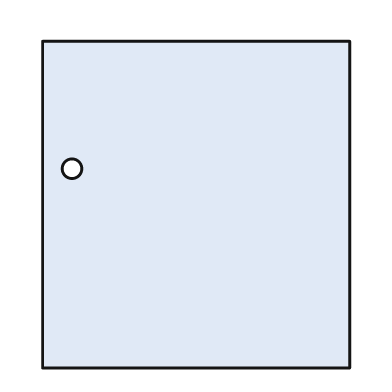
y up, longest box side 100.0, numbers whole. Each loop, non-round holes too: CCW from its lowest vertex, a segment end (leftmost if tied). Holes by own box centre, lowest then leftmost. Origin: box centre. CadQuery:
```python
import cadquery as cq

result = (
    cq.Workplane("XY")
    .moveTo(-47.0, -50.0)
    .lineTo(47.0, -50.0)
    .lineTo(47.0, 50.0)
    .lineTo(-47.0, 50.0)
    .close()
    .moveTo(-38.0, 11.0)
    .circle(3.0)
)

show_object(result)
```